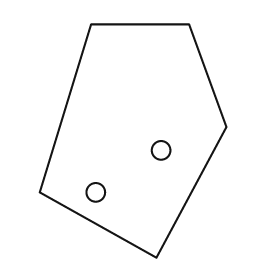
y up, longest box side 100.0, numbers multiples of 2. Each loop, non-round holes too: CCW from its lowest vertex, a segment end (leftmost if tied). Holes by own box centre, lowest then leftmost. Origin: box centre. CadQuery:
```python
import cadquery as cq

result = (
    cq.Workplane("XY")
    .moveTo(10.0, -50.0)
    .lineTo(40.0, 6.0)
    .lineTo(24.0, 50.0)
    .lineTo(-18.0, 50.0)
    .lineTo(-40.0, -22.0)
    .close()
    .moveTo(-16.0, -22.0)
    .circle(4.0)
    .moveTo(12.0, -4.0)
    .circle(4.0)
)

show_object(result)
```